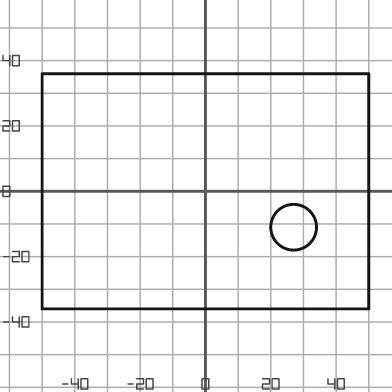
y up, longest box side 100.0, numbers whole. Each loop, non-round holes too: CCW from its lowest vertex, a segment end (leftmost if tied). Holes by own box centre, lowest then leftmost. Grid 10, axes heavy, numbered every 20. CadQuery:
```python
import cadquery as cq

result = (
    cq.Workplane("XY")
    .moveTo(-50.0, -36.0)
    .lineTo(50.0, -36.0)
    .lineTo(50.0, 36.0)
    .lineTo(-50.0, 36.0)
    .close()
    .moveTo(27.0, -11.0)
    .circle(7.0)
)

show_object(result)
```